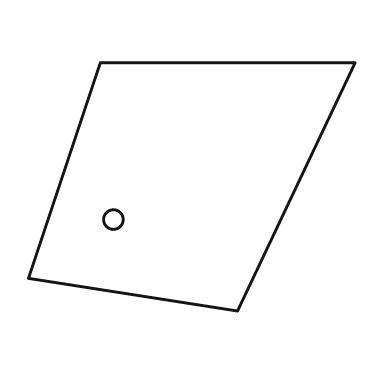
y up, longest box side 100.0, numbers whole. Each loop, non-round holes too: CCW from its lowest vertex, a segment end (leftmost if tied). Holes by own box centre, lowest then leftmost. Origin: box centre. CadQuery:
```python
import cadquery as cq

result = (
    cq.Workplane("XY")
    .moveTo(14.0, -38.0)
    .lineTo(50.0, 38.0)
    .lineTo(-28.0, 38.0)
    .lineTo(-50.0, -28.0)
    .close()
    .moveTo(-24.0, -10.0)
    .circle(3.0)
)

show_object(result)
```